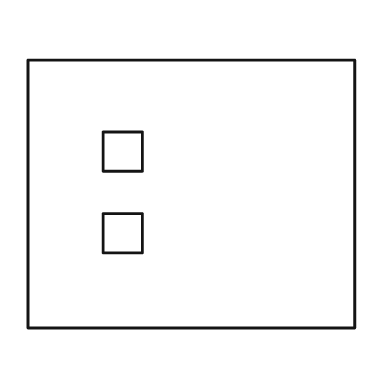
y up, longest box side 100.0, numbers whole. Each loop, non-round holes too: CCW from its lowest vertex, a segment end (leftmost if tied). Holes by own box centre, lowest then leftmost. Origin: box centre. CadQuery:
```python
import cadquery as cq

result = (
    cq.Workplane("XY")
    .moveTo(-50.0, -41.0)
    .lineTo(50.0, -41.0)
    .lineTo(50.0, 41.0)
    .lineTo(-50.0, 41.0)
    .close()
    .moveTo(-27.0, -18.0)
    .lineTo(-15.0, -18.0)
    .lineTo(-15.0, -6.0)
    .lineTo(-27.0, -6.0)
    .close()
    .moveTo(-27.0, 7.0)
    .lineTo(-15.0, 7.0)
    .lineTo(-15.0, 19.0)
    .lineTo(-27.0, 19.0)
    .close()
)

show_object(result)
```